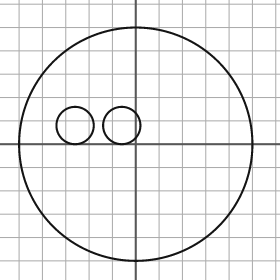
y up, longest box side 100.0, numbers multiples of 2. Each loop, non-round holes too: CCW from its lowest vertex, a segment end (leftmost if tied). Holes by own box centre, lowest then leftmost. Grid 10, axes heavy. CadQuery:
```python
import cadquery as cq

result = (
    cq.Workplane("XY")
    .moveTo(0.0, 0.0)
    .circle(50.0)
    .moveTo(-26.0, 8.0)
    .circle(8.0)
    .moveTo(-6.0, 8.0)
    .circle(8.0)
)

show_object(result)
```